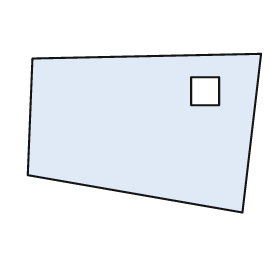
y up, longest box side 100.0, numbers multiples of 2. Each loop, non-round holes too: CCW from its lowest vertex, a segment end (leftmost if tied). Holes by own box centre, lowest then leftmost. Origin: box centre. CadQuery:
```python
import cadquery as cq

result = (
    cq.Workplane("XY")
    .moveTo(42.0, -34.0)
    .lineTo(50.0, 34.0)
    .lineTo(-48.0, 32.0)
    .lineTo(-50.0, -18.0)
    .close()
    .moveTo(20.0, 12.0)
    .lineTo(32.0, 12.0)
    .lineTo(32.0, 24.0)
    .lineTo(20.0, 24.0)
    .close()
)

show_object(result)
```